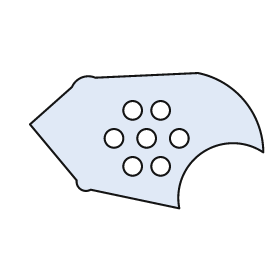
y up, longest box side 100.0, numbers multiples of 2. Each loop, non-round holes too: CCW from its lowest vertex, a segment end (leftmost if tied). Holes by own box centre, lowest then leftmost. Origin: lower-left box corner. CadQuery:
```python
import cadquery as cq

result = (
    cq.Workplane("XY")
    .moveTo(64.0, 0.0)
    .threePointArc((74.0, 24.0), (100.0, 24.0))
    .threePointArc((92.0, 46.0), (72.0, 58.0))
    .lineTo(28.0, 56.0)
    .threePointArc((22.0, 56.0), (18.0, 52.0))
    .lineTo(0.0, 36.0)
    .lineTo(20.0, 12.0)
    .threePointArc((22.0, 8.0), (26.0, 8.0))
    .close()
    .moveTo(44.0, 18.0)
    .circle(4.0)
    .moveTo(56.0, 18.0)
    .circle(4.0)
    .moveTo(36.0, 30.0)
    .circle(4.0)
    .moveTo(50.0, 30.0)
    .circle(4.0)
    .moveTo(64.0, 30.0)
    .circle(4.0)
    .moveTo(44.0, 42.0)
    .circle(4.0)
    .moveTo(56.0, 42.0)
    .circle(4.0)
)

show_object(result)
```